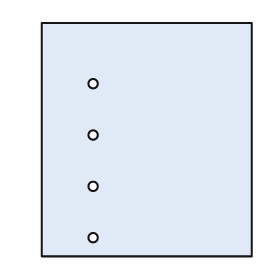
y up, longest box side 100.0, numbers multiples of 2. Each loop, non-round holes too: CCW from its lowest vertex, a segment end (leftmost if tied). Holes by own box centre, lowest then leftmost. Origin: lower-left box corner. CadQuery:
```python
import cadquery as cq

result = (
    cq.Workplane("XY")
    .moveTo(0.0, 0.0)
    .lineTo(90.0, 0.0)
    .lineTo(90.0, 100.0)
    .lineTo(0.0, 100.0)
    .close()
    .moveTo(22.0, 8.0)
    .circle(2.0)
    .moveTo(22.0, 30.0)
    .circle(2.0)
    .moveTo(22.0, 52.0)
    .circle(2.0)
    .moveTo(22.0, 74.0)
    .circle(2.0)
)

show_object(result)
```